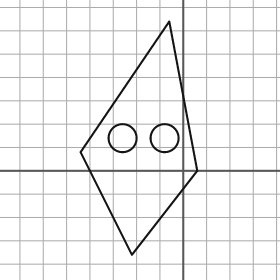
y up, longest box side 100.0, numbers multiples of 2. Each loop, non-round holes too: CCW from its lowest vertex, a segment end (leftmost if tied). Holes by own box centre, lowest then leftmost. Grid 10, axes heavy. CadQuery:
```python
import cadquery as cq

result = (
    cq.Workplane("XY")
    .moveTo(-22.0, -36.0)
    .lineTo(6.0, 0.0)
    .lineTo(-6.0, 64.0)
    .lineTo(-44.0, 8.0)
    .close()
    .moveTo(-26.0, 14.0)
    .circle(6.0)
    .moveTo(-8.0, 14.0)
    .circle(6.0)
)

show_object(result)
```